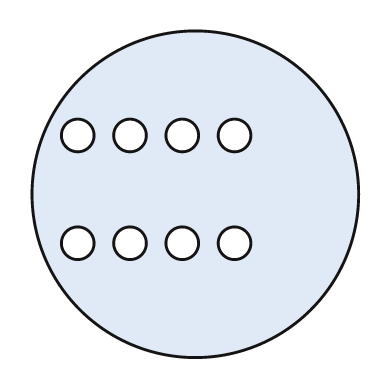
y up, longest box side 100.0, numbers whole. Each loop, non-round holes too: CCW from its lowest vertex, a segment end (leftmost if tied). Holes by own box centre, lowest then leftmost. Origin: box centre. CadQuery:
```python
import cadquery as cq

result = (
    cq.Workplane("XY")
    .moveTo(0.0, 0.0)
    .circle(50.0)
    .moveTo(-36.0, -15.0)
    .circle(5.0)
    .moveTo(-20.0, -15.0)
    .circle(5.0)
    .moveTo(-4.0, -15.0)
    .circle(5.0)
    .moveTo(12.0, -15.0)
    .circle(5.0)
    .moveTo(-36.0, 18.0)
    .circle(5.0)
    .moveTo(-20.0, 18.0)
    .circle(5.0)
    .moveTo(-4.0, 18.0)
    .circle(5.0)
    .moveTo(12.0, 18.0)
    .circle(5.0)
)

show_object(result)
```